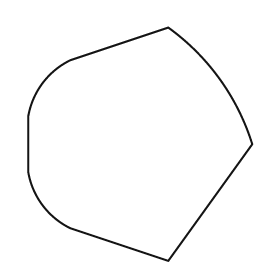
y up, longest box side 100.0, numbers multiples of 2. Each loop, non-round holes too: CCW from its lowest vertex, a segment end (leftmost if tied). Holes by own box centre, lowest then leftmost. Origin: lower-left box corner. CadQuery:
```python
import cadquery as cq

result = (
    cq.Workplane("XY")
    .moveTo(60.0, 0.0)
    .lineTo(96.0, 50.0)
    .threePointArc((82.0, 78.0), (60.0, 100.0))
    .lineTo(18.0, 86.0)
    .threePointArc((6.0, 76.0), (0.0, 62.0))
    .lineTo(0.0, 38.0)
    .threePointArc((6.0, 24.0), (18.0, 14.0))
    .close()
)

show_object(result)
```